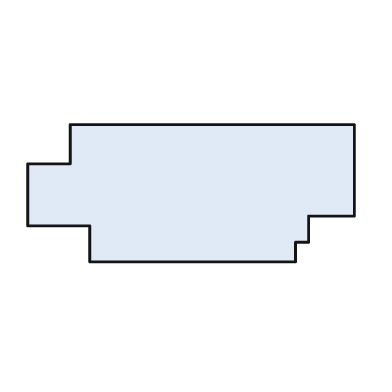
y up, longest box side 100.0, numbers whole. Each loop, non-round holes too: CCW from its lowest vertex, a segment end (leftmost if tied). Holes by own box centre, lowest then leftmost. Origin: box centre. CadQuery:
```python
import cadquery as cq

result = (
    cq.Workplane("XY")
    .moveTo(-31.0, -21.0)
    .lineTo(32.0, -21.0)
    .lineTo(32.0, -15.0)
    .lineTo(36.0, -15.0)
    .lineTo(36.0, -7.0)
    .lineTo(50.0, -7.0)
    .lineTo(50.0, 21.0)
    .lineTo(-37.0, 21.0)
    .lineTo(-37.0, 9.0)
    .lineTo(-50.0, 9.0)
    .lineTo(-50.0, -10.0)
    .lineTo(-31.0, -10.0)
    .close()
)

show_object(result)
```